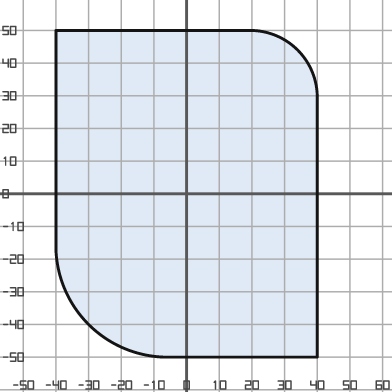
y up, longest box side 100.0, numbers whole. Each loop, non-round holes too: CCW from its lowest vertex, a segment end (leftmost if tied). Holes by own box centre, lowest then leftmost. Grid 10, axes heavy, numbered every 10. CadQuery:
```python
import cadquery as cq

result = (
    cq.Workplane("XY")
    .moveTo(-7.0, -50.0)
    .lineTo(40.0, -50.0)
    .lineTo(40.0, 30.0)
    .threePointArc((34.0, 44.0), (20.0, 50.0))
    .lineTo(-40.0, 50.0)
    .lineTo(-40.0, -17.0)
    .threePointArc((-30.0, -40.0), (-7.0, -50.0))
    .close()
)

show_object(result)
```